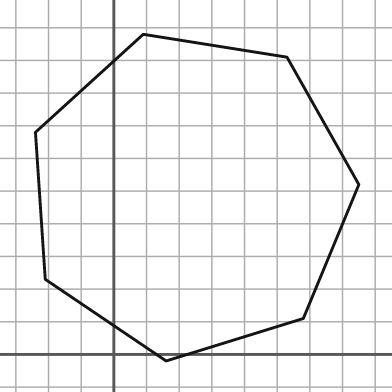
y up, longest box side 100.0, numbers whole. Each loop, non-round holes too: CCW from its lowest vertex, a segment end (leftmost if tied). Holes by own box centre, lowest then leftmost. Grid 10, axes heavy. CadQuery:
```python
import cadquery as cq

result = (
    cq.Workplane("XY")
    .moveTo(16.0, -2.0)
    .lineTo(58.0, 11.0)
    .lineTo(75.0, 52.0)
    .lineTo(53.0, 91.0)
    .lineTo(9.0, 98.0)
    .lineTo(-24.0, 68.0)
    .lineTo(-21.0, 23.0)
    .close()
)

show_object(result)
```